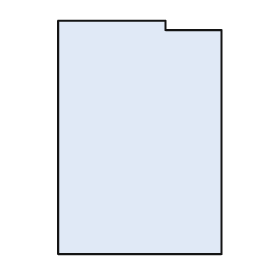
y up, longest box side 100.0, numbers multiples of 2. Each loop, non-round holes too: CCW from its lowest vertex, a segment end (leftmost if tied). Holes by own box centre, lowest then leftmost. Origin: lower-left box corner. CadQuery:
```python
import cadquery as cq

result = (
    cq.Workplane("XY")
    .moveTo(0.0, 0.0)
    .lineTo(70.0, 0.0)
    .lineTo(70.0, 96.0)
    .lineTo(46.0, 96.0)
    .lineTo(46.0, 100.0)
    .lineTo(0.0, 100.0)
    .close()
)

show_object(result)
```